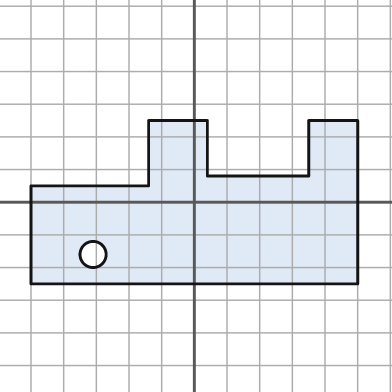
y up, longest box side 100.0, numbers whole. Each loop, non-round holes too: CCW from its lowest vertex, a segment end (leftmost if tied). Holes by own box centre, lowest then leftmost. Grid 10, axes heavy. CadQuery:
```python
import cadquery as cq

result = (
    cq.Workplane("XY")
    .moveTo(-50.0, -25.0)
    .lineTo(50.0, -25.0)
    .lineTo(50.0, 25.0)
    .lineTo(35.0, 25.0)
    .lineTo(35.0, 8.0)
    .lineTo(4.0, 8.0)
    .lineTo(4.0, 25.0)
    .lineTo(-14.0, 25.0)
    .lineTo(-14.0, 5.0)
    .lineTo(-50.0, 5.0)
    .close()
    .moveTo(-31.0, -16.0)
    .circle(4.0)
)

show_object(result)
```